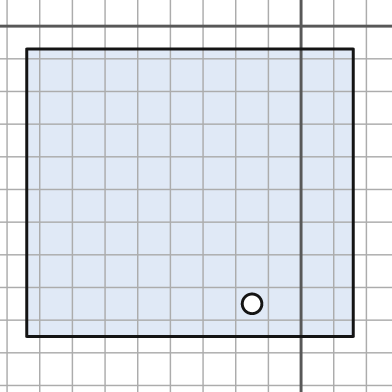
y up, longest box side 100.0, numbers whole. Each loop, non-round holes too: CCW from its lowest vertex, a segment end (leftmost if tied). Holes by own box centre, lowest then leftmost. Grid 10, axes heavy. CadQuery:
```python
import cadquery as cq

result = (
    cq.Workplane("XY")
    .moveTo(-84.0, -95.0)
    .lineTo(16.0, -95.0)
    .lineTo(16.0, -7.0)
    .lineTo(-84.0, -7.0)
    .close()
    .moveTo(-15.0, -85.0)
    .circle(3.0)
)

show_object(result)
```